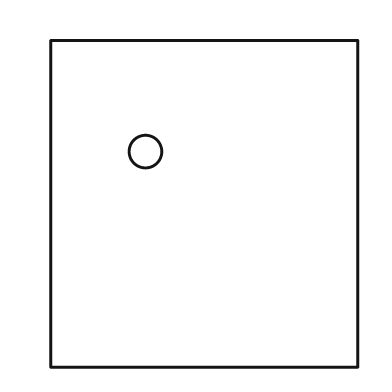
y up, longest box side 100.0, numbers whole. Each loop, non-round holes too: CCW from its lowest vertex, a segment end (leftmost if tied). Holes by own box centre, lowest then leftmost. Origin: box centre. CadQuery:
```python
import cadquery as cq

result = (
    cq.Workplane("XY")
    .moveTo(-47.0, -50.0)
    .lineTo(47.0, -50.0)
    .lineTo(47.0, 50.0)
    .lineTo(-47.0, 50.0)
    .close()
    .moveTo(-18.0, 16.0)
    .circle(5.0)
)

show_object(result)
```